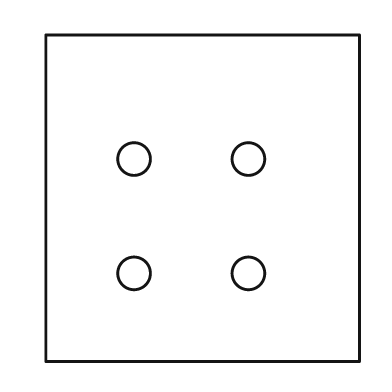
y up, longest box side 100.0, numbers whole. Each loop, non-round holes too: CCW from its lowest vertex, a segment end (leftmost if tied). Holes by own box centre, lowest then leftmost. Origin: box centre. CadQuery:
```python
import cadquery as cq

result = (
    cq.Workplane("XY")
    .moveTo(-48.0, -50.0)
    .lineTo(48.0, -50.0)
    .lineTo(48.0, 50.0)
    .lineTo(-48.0, 50.0)
    .close()
    .moveTo(-21.0, -23.0)
    .circle(5.0)
    .moveTo(14.0, -23.0)
    .circle(5.0)
    .moveTo(-21.0, 12.0)
    .circle(5.0)
    .moveTo(14.0, 12.0)
    .circle(5.0)
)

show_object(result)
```